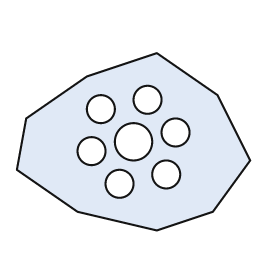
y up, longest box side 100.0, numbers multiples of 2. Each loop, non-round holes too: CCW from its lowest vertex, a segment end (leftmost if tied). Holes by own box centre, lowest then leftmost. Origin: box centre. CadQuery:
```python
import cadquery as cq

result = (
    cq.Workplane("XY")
    .moveTo(10.0, -38.0)
    .lineTo(34.0, -30.0)
    .lineTo(50.0, -8.0)
    .lineTo(36.0, 20.0)
    .lineTo(10.0, 38.0)
    .lineTo(-20.0, 28.0)
    .lineTo(-46.0, 10.0)
    .lineTo(-50.0, -12.0)
    .lineTo(-24.0, -30.0)
    .close()
    .moveTo(-6.0, -18.0)
    .circle(6.0)
    .moveTo(14.0, -14.0)
    .circle(6.0)
    .moveTo(-18.0, -4.0)
    .circle(6.0)
    .moveTo(0.0, 0.0)
    .circle(8.0)
    .moveTo(18.0, 4.0)
    .circle(6.0)
    .moveTo(-14.0, 14.0)
    .circle(6.0)
    .moveTo(6.0, 18.0)
    .circle(6.0)
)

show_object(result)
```